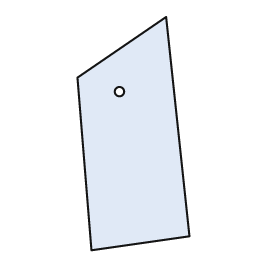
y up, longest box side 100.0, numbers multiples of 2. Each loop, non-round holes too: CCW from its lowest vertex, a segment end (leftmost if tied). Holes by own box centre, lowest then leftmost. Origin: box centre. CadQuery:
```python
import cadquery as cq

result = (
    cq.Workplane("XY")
    .moveTo(-18.0, -50.0)
    .lineTo(24.0, -44.0)
    .lineTo(14.0, 50.0)
    .lineTo(-24.0, 24.0)
    .close()
    .moveTo(-6.0, 18.0)
    .circle(2.0)
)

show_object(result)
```